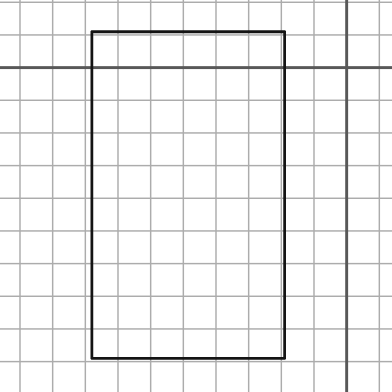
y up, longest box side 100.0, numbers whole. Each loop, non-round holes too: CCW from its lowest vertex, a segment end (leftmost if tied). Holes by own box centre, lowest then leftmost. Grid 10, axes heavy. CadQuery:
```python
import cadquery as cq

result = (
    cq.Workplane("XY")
    .moveTo(-78.0, -89.0)
    .lineTo(-19.0, -89.0)
    .lineTo(-19.0, 11.0)
    .lineTo(-78.0, 11.0)
    .close()
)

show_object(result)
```